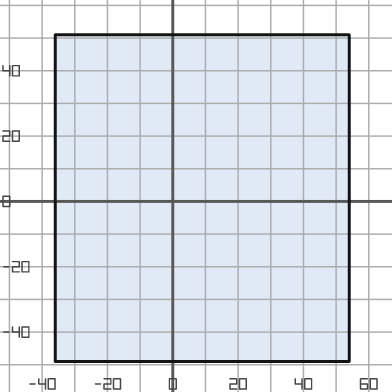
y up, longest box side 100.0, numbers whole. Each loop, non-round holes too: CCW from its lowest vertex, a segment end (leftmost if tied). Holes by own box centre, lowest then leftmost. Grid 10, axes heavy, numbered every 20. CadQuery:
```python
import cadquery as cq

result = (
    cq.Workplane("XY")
    .moveTo(-36.0, -49.0)
    .lineTo(54.0, -49.0)
    .lineTo(54.0, 51.0)
    .lineTo(-36.0, 51.0)
    .close()
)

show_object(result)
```